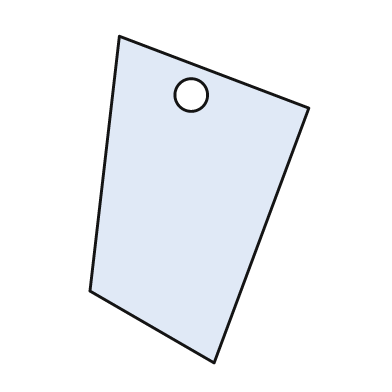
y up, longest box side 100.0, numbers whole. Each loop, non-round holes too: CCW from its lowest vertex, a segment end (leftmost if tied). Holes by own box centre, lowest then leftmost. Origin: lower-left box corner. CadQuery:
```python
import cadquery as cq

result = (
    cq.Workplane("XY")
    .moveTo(38.0, 0.0)
    .lineTo(67.0, 78.0)
    .lineTo(9.0, 100.0)
    .lineTo(0.0, 22.0)
    .close()
    .moveTo(31.0, 82.0)
    .circle(5.0)
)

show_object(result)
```